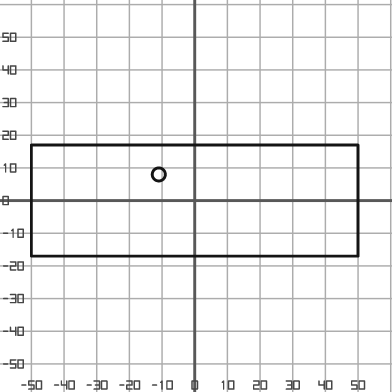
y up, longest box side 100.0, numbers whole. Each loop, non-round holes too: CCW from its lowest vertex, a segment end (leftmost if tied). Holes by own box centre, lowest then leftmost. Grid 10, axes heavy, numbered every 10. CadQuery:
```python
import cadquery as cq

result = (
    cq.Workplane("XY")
    .moveTo(-50.0, -17.0)
    .lineTo(50.0, -17.0)
    .lineTo(50.0, 17.0)
    .lineTo(-50.0, 17.0)
    .close()
    .moveTo(-11.0, 8.0)
    .circle(2.0)
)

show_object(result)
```